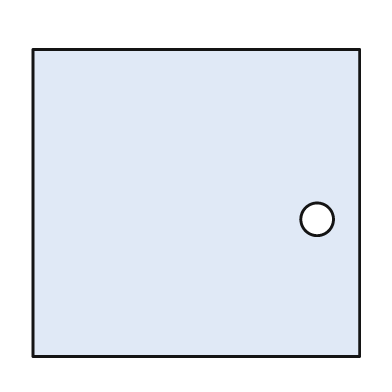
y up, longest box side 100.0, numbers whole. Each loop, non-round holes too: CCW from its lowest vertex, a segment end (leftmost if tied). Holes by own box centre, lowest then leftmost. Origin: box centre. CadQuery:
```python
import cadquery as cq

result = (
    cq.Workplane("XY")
    .moveTo(-50.0, -47.0)
    .lineTo(50.0, -47.0)
    .lineTo(50.0, 47.0)
    .lineTo(-50.0, 47.0)
    .close()
    .moveTo(37.0, -5.0)
    .circle(5.0)
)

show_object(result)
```